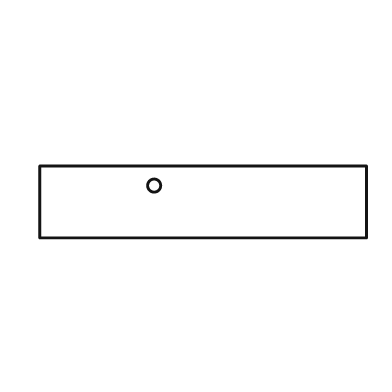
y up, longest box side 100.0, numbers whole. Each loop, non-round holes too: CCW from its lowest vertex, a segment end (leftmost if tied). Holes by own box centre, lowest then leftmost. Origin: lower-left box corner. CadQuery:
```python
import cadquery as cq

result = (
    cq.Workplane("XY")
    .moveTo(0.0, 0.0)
    .lineTo(100.0, 0.0)
    .lineTo(100.0, 22.0)
    .lineTo(0.0, 22.0)
    .close()
    .moveTo(35.0, 16.0)
    .circle(2.0)
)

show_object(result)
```